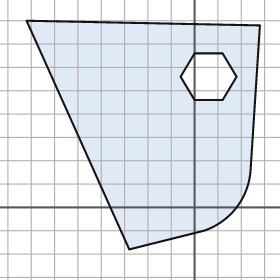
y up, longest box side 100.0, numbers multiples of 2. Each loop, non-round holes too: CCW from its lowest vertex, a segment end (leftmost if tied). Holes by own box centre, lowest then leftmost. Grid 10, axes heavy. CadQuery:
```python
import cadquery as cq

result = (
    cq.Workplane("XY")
    .moveTo(-28.0, -18.0)
    .lineTo(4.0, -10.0)
    .threePointArc((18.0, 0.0), (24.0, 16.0))
    .lineTo(28.0, 78.0)
    .lineTo(-72.0, 80.0)
    .close()
    .moveTo(0.0, 46.0)
    .lineTo(12.0, 46.0)
    .lineTo(18.0, 56.0)
    .lineTo(12.0, 66.0)
    .lineTo(0.0, 66.0)
    .lineTo(-6.0, 56.0)
    .close()
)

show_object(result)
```